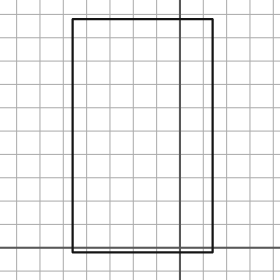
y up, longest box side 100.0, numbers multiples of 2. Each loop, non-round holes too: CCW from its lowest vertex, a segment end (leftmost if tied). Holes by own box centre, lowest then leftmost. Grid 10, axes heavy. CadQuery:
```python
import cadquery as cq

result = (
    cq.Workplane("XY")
    .moveTo(-46.0, -2.0)
    .lineTo(14.0, -2.0)
    .lineTo(14.0, 98.0)
    .lineTo(-46.0, 98.0)
    .close()
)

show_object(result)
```